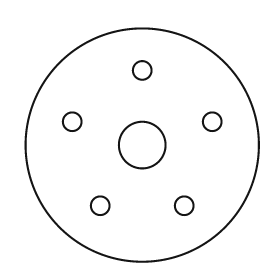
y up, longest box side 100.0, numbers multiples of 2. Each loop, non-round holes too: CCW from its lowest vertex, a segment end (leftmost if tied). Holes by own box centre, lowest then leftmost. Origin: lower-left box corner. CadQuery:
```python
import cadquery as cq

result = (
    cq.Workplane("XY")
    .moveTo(50.0, 50.0)
    .circle(50.0)
    .moveTo(32.0, 24.0)
    .circle(4.0)
    .moveTo(68.0, 24.0)
    .circle(4.0)
    .moveTo(50.0, 50.0)
    .circle(10.0)
    .moveTo(20.0, 60.0)
    .circle(4.0)
    .moveTo(80.0, 60.0)
    .circle(4.0)
    .moveTo(50.0, 82.0)
    .circle(4.0)
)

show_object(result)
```